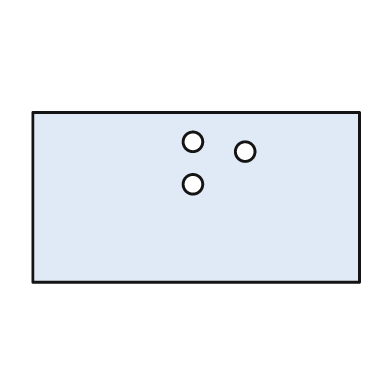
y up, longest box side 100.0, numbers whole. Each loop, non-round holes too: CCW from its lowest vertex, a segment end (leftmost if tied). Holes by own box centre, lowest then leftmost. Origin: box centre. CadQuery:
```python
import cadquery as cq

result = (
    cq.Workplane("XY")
    .moveTo(-50.0, -26.0)
    .lineTo(50.0, -26.0)
    .lineTo(50.0, 26.0)
    .lineTo(-50.0, 26.0)
    .close()
    .moveTo(-1.0, 4.0)
    .circle(3.0)
    .moveTo(15.0, 14.0)
    .circle(3.0)
    .moveTo(-1.0, 17.0)
    .circle(3.0)
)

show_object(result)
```